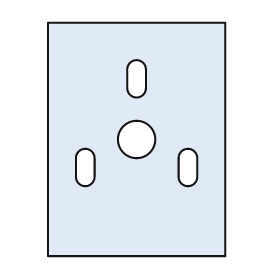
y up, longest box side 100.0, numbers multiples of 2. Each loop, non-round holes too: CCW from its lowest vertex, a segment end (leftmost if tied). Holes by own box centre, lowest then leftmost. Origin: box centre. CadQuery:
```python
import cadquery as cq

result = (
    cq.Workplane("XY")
    .moveTo(-38.0, -50.0)
    .lineTo(38.0, -50.0)
    .lineTo(38.0, 50.0)
    .lineTo(-38.0, 50.0)
    .close()
    .moveTo(-26.0, -16.0)
    .threePointArc((-22.0, -20.0), (-18.0, -16.0))
    .lineTo(-18.0, -8.0)
    .threePointArc((-22.0, -4.0), (-26.0, -8.0))
    .close()
    .moveTo(18.0, -16.0)
    .threePointArc((22.0, -20.0), (26.0, -16.0))
    .lineTo(26.0, -8.0)
    .threePointArc((22.0, -4.0), (18.0, -8.0))
    .close()
    .moveTo(0.0, 0.0)
    .circle(8.0)
    .moveTo(-4.0, 22.0)
    .threePointArc((0.0, 18.0), (4.0, 22.0))
    .lineTo(4.0, 30.0)
    .threePointArc((0.0, 34.0), (-4.0, 30.0))
    .close()
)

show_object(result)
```